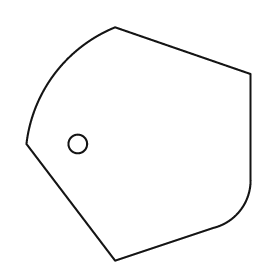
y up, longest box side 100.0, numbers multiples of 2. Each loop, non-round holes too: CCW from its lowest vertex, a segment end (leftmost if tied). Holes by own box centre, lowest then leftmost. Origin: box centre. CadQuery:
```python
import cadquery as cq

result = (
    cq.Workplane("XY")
    .moveTo(-10.0, -50.0)
    .lineTo(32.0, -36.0)
    .threePointArc((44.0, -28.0), (48.0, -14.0))
    .lineTo(48.0, 30.0)
    .lineTo(-10.0, 50.0)
    .threePointArc((-36.0, 30.0), (-48.0, 0.0))
    .close()
    .moveTo(-26.0, 0.0)
    .circle(4.0)
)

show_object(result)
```